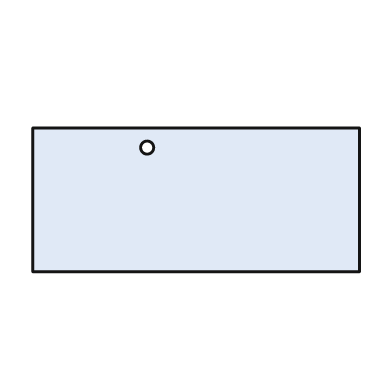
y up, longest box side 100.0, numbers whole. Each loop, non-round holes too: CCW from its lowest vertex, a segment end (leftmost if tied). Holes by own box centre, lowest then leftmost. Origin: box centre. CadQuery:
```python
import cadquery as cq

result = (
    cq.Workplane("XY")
    .moveTo(-50.0, -22.0)
    .lineTo(50.0, -22.0)
    .lineTo(50.0, 22.0)
    .lineTo(-50.0, 22.0)
    .close()
    .moveTo(-15.0, 16.0)
    .circle(2.0)
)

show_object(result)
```